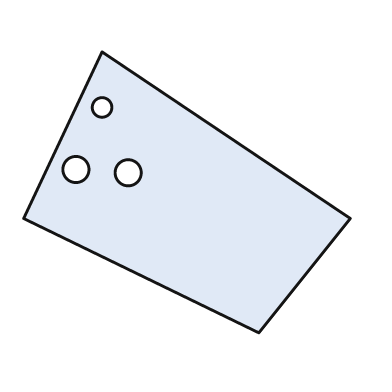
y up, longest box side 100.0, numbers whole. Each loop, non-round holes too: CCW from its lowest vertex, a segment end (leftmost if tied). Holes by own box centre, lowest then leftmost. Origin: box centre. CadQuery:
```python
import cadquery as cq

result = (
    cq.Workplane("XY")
    .moveTo(22.0, -43.0)
    .lineTo(50.0, -8.0)
    .lineTo(-26.0, 43.0)
    .lineTo(-50.0, -8.0)
    .close()
    .moveTo(-18.0, 6.0)
    .circle(4.0)
    .moveTo(-34.0, 7.0)
    .circle(4.0)
    .moveTo(-26.0, 26.0)
    .circle(3.0)
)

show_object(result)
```